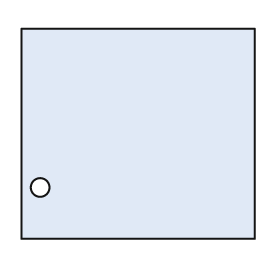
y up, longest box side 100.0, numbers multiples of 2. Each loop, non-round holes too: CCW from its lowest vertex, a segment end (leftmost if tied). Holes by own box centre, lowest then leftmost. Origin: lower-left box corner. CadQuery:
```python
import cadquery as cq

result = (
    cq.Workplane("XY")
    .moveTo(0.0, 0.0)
    .lineTo(100.0, 0.0)
    .lineTo(100.0, 90.0)
    .lineTo(0.0, 90.0)
    .close()
    .moveTo(8.0, 22.0)
    .circle(4.0)
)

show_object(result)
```